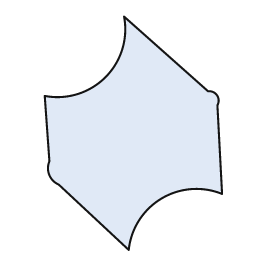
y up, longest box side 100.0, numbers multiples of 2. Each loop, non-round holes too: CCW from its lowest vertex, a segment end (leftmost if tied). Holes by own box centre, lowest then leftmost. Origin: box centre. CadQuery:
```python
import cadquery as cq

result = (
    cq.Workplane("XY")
    .moveTo(-2.0, -50.0)
    .threePointArc((12.0, -28.0), (38.0, -26.0))
    .lineTo(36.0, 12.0)
    .threePointArc((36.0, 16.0), (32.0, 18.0))
    .lineTo(-4.0, 50.0)
    .threePointArc((-12.0, 24.0), (-38.0, 16.0))
    .lineTo(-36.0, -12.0)
    .threePointArc((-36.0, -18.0), (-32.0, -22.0))
    .close()
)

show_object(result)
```